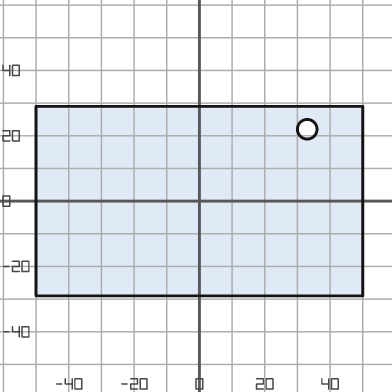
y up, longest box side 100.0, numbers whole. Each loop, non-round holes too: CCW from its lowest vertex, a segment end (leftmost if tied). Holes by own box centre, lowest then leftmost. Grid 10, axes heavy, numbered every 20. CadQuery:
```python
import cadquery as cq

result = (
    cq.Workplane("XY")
    .moveTo(-50.0, -29.0)
    .lineTo(50.0, -29.0)
    .lineTo(50.0, 29.0)
    .lineTo(-50.0, 29.0)
    .close()
    .moveTo(33.0, 22.0)
    .circle(3.0)
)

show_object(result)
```